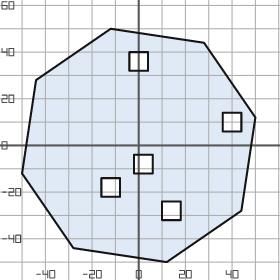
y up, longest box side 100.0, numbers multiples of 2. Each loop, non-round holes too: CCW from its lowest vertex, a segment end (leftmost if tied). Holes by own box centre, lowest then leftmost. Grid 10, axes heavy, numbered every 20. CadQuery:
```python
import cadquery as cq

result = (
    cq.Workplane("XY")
    .moveTo(12.0, -50.0)
    .lineTo(44.0, -28.0)
    .lineTo(50.0, 12.0)
    .lineTo(28.0, 44.0)
    .lineTo(-12.0, 50.0)
    .lineTo(-44.0, 28.0)
    .lineTo(-50.0, -12.0)
    .lineTo(-28.0, -44.0)
    .close()
    .moveTo(10.0, -32.0)
    .lineTo(18.0, -32.0)
    .lineTo(18.0, -24.0)
    .lineTo(10.0, -24.0)
    .close()
    .moveTo(-16.0, -22.0)
    .lineTo(-8.0, -22.0)
    .lineTo(-8.0, -14.0)
    .lineTo(-16.0, -14.0)
    .close()
    .moveTo(-2.0, -12.0)
    .lineTo(6.0, -12.0)
    .lineTo(6.0, -4.0)
    .lineTo(-2.0, -4.0)
    .close()
    .moveTo(36.0, 6.0)
    .lineTo(44.0, 6.0)
    .lineTo(44.0, 14.0)
    .lineTo(36.0, 14.0)
    .close()
    .moveTo(-4.0, 32.0)
    .lineTo(4.0, 32.0)
    .lineTo(4.0, 40.0)
    .lineTo(-4.0, 40.0)
    .close()
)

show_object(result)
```